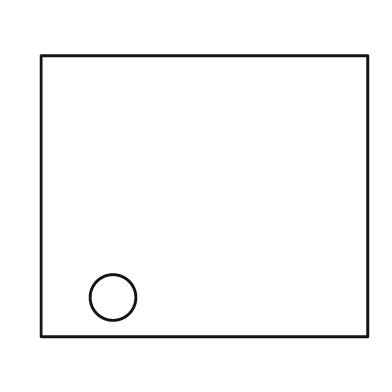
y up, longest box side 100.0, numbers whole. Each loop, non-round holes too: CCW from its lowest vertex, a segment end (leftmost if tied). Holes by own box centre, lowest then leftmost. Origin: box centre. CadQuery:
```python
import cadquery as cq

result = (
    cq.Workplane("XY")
    .moveTo(-50.0, -43.0)
    .lineTo(50.0, -43.0)
    .lineTo(50.0, 43.0)
    .lineTo(-50.0, 43.0)
    .close()
    .moveTo(-28.0, -31.0)
    .circle(7.0)
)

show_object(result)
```